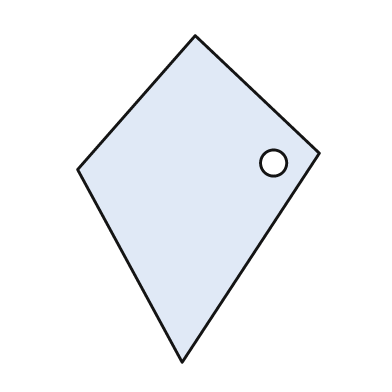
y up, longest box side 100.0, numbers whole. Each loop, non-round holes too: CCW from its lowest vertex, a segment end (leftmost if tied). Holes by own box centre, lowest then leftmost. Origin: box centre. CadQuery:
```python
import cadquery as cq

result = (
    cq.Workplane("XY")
    .moveTo(-5.0, -50.0)
    .lineTo(37.0, 14.0)
    .lineTo(-1.0, 50.0)
    .lineTo(-37.0, 9.0)
    .close()
    .moveTo(23.0, 11.0)
    .circle(4.0)
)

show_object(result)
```